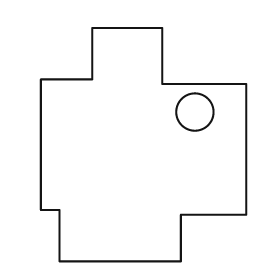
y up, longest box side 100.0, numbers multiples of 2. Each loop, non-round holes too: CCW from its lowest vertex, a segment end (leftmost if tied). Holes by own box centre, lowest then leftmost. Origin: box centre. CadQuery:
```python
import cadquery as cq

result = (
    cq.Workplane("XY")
    .moveTo(-36.0, -50.0)
    .lineTo(16.0, -50.0)
    .lineTo(16.0, -30.0)
    .lineTo(44.0, -30.0)
    .lineTo(44.0, 26.0)
    .lineTo(8.0, 26.0)
    .lineTo(8.0, 50.0)
    .lineTo(-22.0, 50.0)
    .lineTo(-22.0, 28.0)
    .lineTo(-44.0, 28.0)
    .lineTo(-44.0, -28.0)
    .lineTo(-36.0, -28.0)
    .close()
    .moveTo(22.0, 14.0)
    .circle(8.0)
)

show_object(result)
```